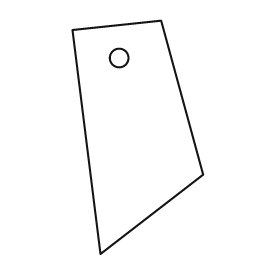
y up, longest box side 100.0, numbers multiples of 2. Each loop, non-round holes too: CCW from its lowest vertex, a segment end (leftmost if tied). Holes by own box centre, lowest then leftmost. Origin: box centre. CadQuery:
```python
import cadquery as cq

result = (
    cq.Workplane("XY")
    .moveTo(-16.0, -50.0)
    .lineTo(28.0, -16.0)
    .lineTo(10.0, 50.0)
    .lineTo(-28.0, 46.0)
    .close()
    .moveTo(-8.0, 34.0)
    .circle(4.0)
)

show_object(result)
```